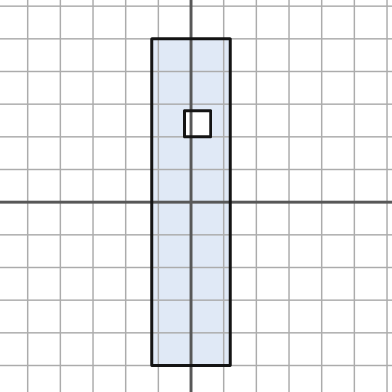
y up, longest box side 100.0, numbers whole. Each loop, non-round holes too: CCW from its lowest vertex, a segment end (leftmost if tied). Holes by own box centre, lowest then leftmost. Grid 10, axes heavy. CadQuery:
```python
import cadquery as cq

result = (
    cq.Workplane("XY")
    .moveTo(-12.0, -50.0)
    .lineTo(12.0, -50.0)
    .lineTo(12.0, 50.0)
    .lineTo(-12.0, 50.0)
    .close()
    .moveTo(-2.0, 20.0)
    .lineTo(6.0, 20.0)
    .lineTo(6.0, 28.0)
    .lineTo(-2.0, 28.0)
    .close()
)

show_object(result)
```